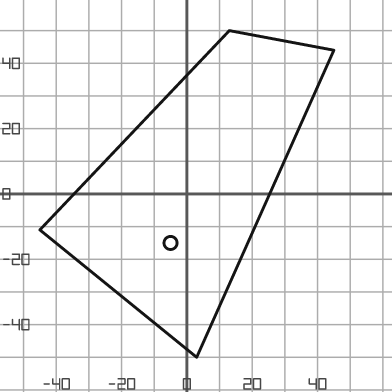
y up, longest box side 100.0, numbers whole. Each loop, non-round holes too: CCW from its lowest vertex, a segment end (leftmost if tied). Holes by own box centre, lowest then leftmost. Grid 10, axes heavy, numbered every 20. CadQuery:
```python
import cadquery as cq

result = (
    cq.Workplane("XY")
    .moveTo(3.0, -50.0)
    .lineTo(45.0, 44.0)
    .lineTo(13.0, 50.0)
    .lineTo(-45.0, -11.0)
    .close()
    .moveTo(-5.0, -15.0)
    .circle(2.0)
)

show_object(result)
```